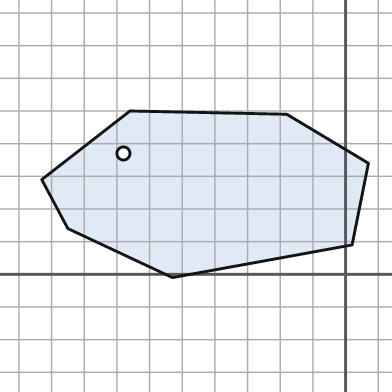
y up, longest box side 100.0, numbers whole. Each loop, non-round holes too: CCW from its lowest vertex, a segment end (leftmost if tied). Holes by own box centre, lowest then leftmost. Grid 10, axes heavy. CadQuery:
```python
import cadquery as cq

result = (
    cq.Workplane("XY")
    .moveTo(-53.0, -1.0)
    .lineTo(2.0, 9.0)
    .lineTo(7.0, 34.0)
    .lineTo(-18.0, 49.0)
    .lineTo(-66.0, 50.0)
    .lineTo(-93.0, 29.0)
    .lineTo(-85.0, 14.0)
    .close()
    .moveTo(-68.0, 37.0)
    .circle(2.0)
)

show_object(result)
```